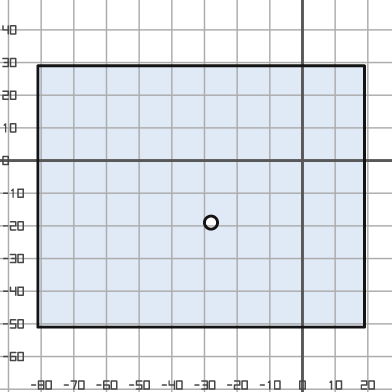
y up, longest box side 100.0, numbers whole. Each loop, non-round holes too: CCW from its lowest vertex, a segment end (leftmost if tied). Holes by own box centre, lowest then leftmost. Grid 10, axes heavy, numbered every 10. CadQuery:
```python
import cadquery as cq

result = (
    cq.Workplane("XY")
    .moveTo(-81.0, -51.0)
    .lineTo(19.0, -51.0)
    .lineTo(19.0, 29.0)
    .lineTo(-81.0, 29.0)
    .close()
    .moveTo(-28.0, -19.0)
    .circle(2.0)
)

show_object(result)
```